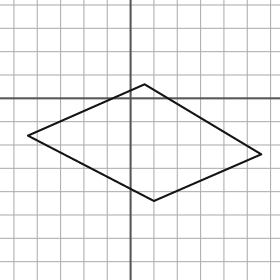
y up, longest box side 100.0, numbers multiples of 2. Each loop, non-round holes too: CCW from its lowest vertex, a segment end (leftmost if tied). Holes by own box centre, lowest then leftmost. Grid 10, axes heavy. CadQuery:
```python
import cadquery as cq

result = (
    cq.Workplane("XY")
    .moveTo(10.0, -44.0)
    .lineTo(56.0, -24.0)
    .lineTo(6.0, 6.0)
    .lineTo(-44.0, -16.0)
    .close()
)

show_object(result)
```